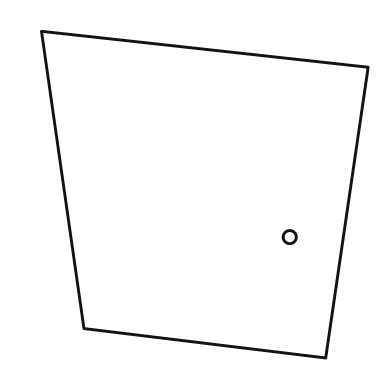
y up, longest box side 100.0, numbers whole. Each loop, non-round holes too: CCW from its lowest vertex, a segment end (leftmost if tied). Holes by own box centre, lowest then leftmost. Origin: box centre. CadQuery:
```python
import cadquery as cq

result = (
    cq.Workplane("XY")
    .moveTo(37.0, -50.0)
    .lineTo(50.0, 39.0)
    .lineTo(-50.0, 50.0)
    .lineTo(-37.0, -41.0)
    .close()
    .moveTo(26.0, -13.0)
    .circle(2.0)
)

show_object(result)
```